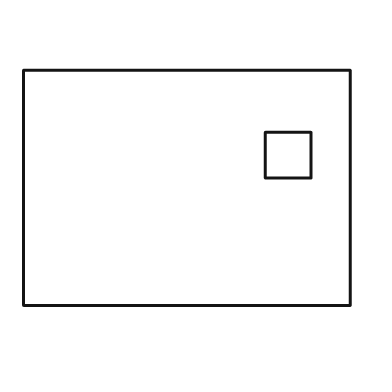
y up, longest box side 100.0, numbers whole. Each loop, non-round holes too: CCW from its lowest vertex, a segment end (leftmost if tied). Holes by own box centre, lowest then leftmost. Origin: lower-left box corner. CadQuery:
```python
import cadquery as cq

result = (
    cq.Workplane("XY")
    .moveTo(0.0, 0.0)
    .lineTo(100.0, 0.0)
    .lineTo(100.0, 72.0)
    .lineTo(0.0, 72.0)
    .close()
    .moveTo(74.0, 39.0)
    .lineTo(88.0, 39.0)
    .lineTo(88.0, 53.0)
    .lineTo(74.0, 53.0)
    .close()
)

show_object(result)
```